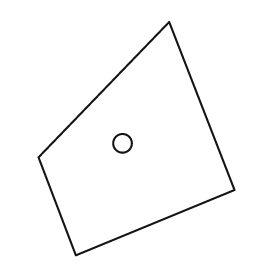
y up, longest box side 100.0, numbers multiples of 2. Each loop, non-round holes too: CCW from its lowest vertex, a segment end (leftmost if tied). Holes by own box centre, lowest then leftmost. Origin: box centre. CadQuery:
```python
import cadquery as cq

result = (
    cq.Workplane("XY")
    .moveTo(-26.0, -50.0)
    .lineTo(42.0, -22.0)
    .lineTo(14.0, 50.0)
    .lineTo(-42.0, -8.0)
    .close()
    .moveTo(-6.0, -2.0)
    .circle(4.0)
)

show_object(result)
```